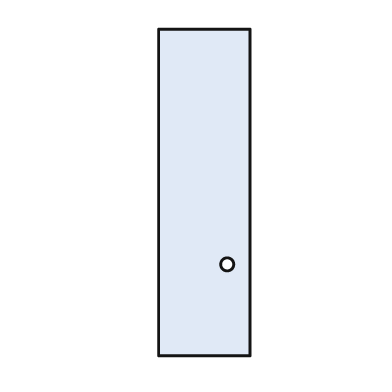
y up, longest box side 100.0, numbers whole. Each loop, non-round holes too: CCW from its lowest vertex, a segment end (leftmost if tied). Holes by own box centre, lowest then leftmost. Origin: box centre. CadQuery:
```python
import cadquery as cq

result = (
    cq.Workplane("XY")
    .moveTo(-14.0, -50.0)
    .lineTo(14.0, -50.0)
    .lineTo(14.0, 50.0)
    .lineTo(-14.0, 50.0)
    .close()
    .moveTo(7.0, -22.0)
    .circle(2.0)
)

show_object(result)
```